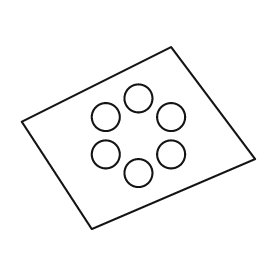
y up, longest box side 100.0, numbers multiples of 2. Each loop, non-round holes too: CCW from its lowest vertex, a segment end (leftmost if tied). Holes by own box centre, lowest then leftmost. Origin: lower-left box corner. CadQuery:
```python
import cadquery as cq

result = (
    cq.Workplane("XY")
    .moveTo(30.0, 0.0)
    .lineTo(100.0, 30.0)
    .lineTo(64.0, 78.0)
    .lineTo(0.0, 46.0)
    .close()
    .moveTo(50.0, 24.0)
    .circle(6.0)
    .moveTo(36.0, 32.0)
    .circle(6.0)
    .moveTo(64.0, 32.0)
    .circle(6.0)
    .moveTo(36.0, 48.0)
    .circle(6.0)
    .moveTo(64.0, 48.0)
    .circle(6.0)
    .moveTo(50.0, 56.0)
    .circle(6.0)
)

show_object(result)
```